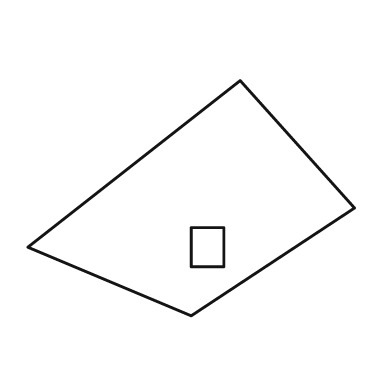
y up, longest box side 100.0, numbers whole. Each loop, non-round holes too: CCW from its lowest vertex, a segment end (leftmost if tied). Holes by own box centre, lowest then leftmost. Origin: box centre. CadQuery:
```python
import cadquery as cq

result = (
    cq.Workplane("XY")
    .moveTo(0.0, -36.0)
    .lineTo(50.0, -3.0)
    .lineTo(15.0, 36.0)
    .lineTo(-50.0, -15.0)
    .close()
    .moveTo(0.0, -21.0)
    .lineTo(10.0, -21.0)
    .lineTo(10.0, -9.0)
    .lineTo(0.0, -9.0)
    .close()
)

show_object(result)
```